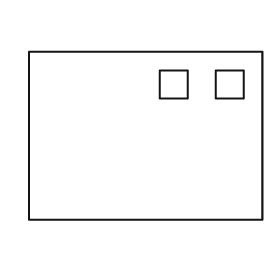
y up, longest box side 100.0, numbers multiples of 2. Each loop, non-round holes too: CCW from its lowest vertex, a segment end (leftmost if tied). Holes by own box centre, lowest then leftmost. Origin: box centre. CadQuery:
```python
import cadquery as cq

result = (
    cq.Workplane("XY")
    .moveTo(-50.0, -36.0)
    .lineTo(50.0, -36.0)
    .lineTo(50.0, 36.0)
    .lineTo(-50.0, 36.0)
    .close()
    .moveTo(6.0, 16.0)
    .lineTo(18.0, 16.0)
    .lineTo(18.0, 28.0)
    .lineTo(6.0, 28.0)
    .close()
    .moveTo(30.0, 16.0)
    .lineTo(42.0, 16.0)
    .lineTo(42.0, 28.0)
    .lineTo(30.0, 28.0)
    .close()
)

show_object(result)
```